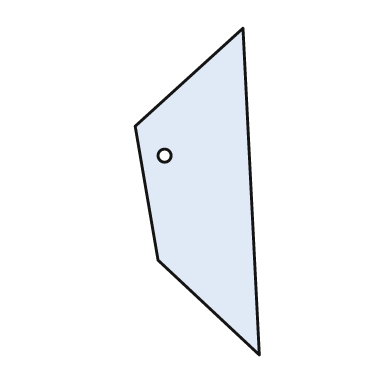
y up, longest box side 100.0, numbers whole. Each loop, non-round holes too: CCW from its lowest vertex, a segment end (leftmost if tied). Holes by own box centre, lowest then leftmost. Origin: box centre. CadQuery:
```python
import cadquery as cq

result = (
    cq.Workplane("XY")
    .moveTo(19.0, -50.0)
    .lineTo(14.0, 50.0)
    .lineTo(-19.0, 20.0)
    .lineTo(-12.0, -21.0)
    .close()
    .moveTo(-10.0, 11.0)
    .circle(2.0)
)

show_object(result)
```